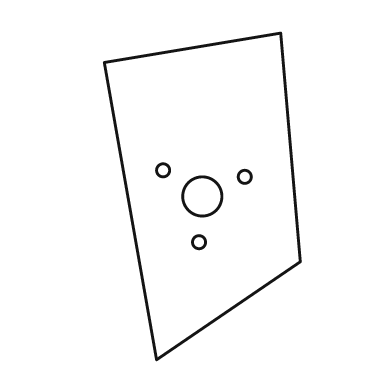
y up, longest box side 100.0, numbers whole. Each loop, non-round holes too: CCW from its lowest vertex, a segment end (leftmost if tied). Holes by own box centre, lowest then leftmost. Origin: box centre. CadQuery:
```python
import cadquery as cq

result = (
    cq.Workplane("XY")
    .moveTo(-14.0, -50.0)
    .lineTo(30.0, -20.0)
    .lineTo(24.0, 50.0)
    .lineTo(-30.0, 41.0)
    .close()
    .moveTo(-1.0, -14.0)
    .circle(2.0)
    .moveTo(0.0, 0.0)
    .circle(6.0)
    .moveTo(13.0, 6.0)
    .circle(2.0)
    .moveTo(-12.0, 8.0)
    .circle(2.0)
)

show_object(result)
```